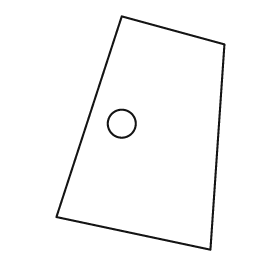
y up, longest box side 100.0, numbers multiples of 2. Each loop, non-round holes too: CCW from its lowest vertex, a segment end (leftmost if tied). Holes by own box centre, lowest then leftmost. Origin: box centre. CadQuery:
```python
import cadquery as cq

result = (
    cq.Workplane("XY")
    .moveTo(30.0, -50.0)
    .lineTo(36.0, 38.0)
    .lineTo(-8.0, 50.0)
    .lineTo(-36.0, -36.0)
    .close()
    .moveTo(-8.0, 4.0)
    .circle(6.0)
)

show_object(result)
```